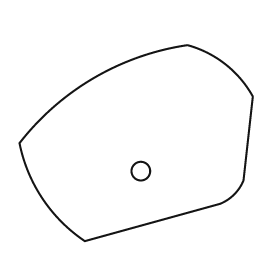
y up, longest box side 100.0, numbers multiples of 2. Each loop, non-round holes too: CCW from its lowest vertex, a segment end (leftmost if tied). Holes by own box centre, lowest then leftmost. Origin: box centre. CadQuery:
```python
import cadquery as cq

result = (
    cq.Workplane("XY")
    .moveTo(-22.0, -42.0)
    .lineTo(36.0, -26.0)
    .threePointArc((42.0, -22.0), (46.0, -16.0))
    .lineTo(50.0, 20.0)
    .threePointArc((38.0, 34.0), (22.0, 42.0))
    .threePointArc((-18.0, 28.0), (-50.0, 0.0))
    .threePointArc((-40.0, -24.0), (-22.0, -42.0))
    .close()
    .moveTo(2.0, -12.0)
    .circle(4.0)
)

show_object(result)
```